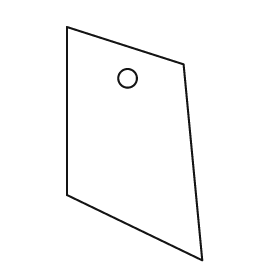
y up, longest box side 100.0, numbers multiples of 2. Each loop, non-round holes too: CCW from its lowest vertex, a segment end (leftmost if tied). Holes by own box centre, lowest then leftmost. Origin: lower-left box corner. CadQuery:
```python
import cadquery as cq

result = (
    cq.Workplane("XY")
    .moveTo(58.0, 0.0)
    .lineTo(50.0, 84.0)
    .lineTo(0.0, 100.0)
    .lineTo(0.0, 28.0)
    .close()
    .moveTo(26.0, 78.0)
    .circle(4.0)
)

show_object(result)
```